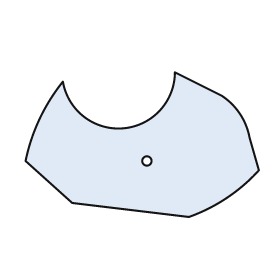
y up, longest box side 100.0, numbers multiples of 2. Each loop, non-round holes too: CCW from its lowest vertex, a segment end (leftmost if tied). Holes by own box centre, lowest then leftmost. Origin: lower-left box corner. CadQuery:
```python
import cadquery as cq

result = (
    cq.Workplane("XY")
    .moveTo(70.0, 0.0)
    .threePointArc((86.0, 8.0), (100.0, 20.0))
    .lineTo(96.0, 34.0)
    .threePointArc((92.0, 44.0), (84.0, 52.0))
    .lineTo(64.0, 62.0)
    .threePointArc((42.0, 38.0), (16.0, 58.0))
    .threePointArc((6.0, 42.0), (0.0, 24.0))
    .lineTo(20.0, 6.0)
    .close()
    .moveTo(52.0, 24.0)
    .circle(2.0)
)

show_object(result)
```